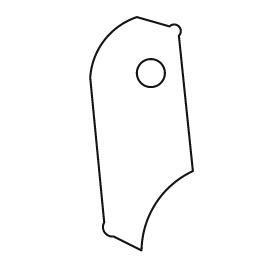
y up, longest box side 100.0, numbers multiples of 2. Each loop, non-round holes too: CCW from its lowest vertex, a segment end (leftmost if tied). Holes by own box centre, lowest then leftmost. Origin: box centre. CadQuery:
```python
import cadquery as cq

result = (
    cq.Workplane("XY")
    .moveTo(0.0, -50.0)
    .threePointArc((6.0, -30.0), (22.0, -16.0))
    .lineTo(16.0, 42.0)
    .threePointArc((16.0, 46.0), (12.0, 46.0))
    .lineTo(-2.0, 50.0)
    .threePointArc((-16.0, 40.0), (-22.0, 24.0))
    .lineTo(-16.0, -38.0)
    .threePointArc((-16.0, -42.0), (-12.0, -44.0))
    .close()
    .moveTo(4.0, 26.0)
    .circle(6.0)
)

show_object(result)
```